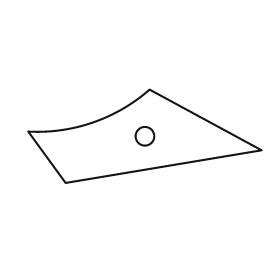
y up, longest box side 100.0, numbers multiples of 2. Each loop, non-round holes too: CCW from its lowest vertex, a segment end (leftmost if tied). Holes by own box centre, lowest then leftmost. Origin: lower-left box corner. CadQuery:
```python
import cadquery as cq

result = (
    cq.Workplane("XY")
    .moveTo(16.0, 0.0)
    .lineTo(100.0, 14.0)
    .lineTo(52.0, 40.0)
    .threePointArc((28.0, 26.0), (0.0, 22.0))
    .close()
    .moveTo(50.0, 20.0)
    .circle(4.0)
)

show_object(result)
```